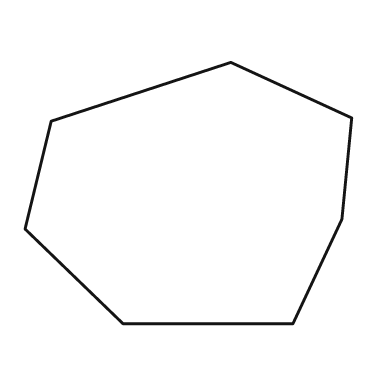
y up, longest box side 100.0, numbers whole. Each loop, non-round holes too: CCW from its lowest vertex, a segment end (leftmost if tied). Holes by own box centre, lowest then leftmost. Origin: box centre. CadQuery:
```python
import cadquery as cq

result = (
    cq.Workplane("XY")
    .moveTo(-20.0, -40.0)
    .lineTo(32.0, -40.0)
    .lineTo(47.0, -8.0)
    .lineTo(50.0, 23.0)
    .lineTo(13.0, 40.0)
    .lineTo(-42.0, 22.0)
    .lineTo(-50.0, -11.0)
    .close()
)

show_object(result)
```